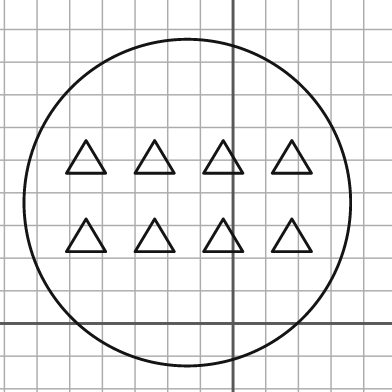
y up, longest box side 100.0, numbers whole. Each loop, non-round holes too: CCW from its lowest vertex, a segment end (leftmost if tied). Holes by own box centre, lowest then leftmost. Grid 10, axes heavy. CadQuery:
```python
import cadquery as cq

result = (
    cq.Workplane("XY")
    .moveTo(-14.0, 37.0)
    .circle(50.0)
    .moveTo(-51.0, 22.0)
    .lineTo(-39.0, 22.0)
    .lineTo(-45.0, 32.0)
    .close()
    .moveTo(-30.0, 22.0)
    .lineTo(-18.0, 22.0)
    .lineTo(-24.0, 32.0)
    .close()
    .moveTo(-9.0, 22.0)
    .lineTo(3.0, 22.0)
    .lineTo(-3.0, 32.0)
    .close()
    .moveTo(12.0, 22.0)
    .lineTo(24.0, 22.0)
    .lineTo(18.0, 32.0)
    .close()
    .moveTo(-51.0, 46.0)
    .lineTo(-39.0, 46.0)
    .lineTo(-45.0, 56.0)
    .close()
    .moveTo(-30.0, 46.0)
    .lineTo(-18.0, 46.0)
    .lineTo(-24.0, 56.0)
    .close()
    .moveTo(-9.0, 46.0)
    .lineTo(3.0, 46.0)
    .lineTo(-3.0, 56.0)
    .close()
    .moveTo(12.0, 46.0)
    .lineTo(24.0, 46.0)
    .lineTo(18.0, 56.0)
    .close()
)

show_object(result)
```